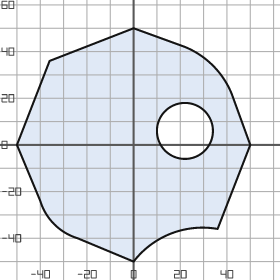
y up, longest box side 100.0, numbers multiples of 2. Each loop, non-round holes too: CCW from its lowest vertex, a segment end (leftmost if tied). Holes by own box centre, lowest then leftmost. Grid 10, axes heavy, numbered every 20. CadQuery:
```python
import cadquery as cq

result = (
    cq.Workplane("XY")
    .moveTo(0.0, -50.0)
    .threePointArc((16.0, -38.0), (36.0, -36.0))
    .lineTo(50.0, 0.0)
    .lineTo(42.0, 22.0)
    .threePointArc((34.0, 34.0), (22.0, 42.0))
    .lineTo(0.0, 50.0)
    .lineTo(-36.0, 36.0)
    .lineTo(-50.0, 0.0)
    .lineTo(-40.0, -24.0)
    .threePointArc((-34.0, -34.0), (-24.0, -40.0))
    .close()
    .moveTo(22.0, 6.0)
    .circle(12.0)
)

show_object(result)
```